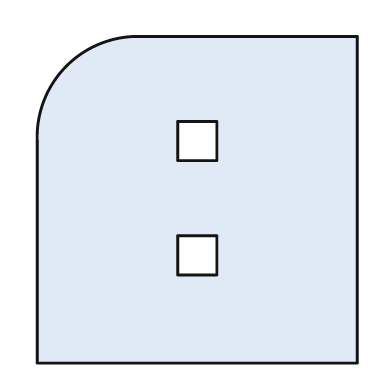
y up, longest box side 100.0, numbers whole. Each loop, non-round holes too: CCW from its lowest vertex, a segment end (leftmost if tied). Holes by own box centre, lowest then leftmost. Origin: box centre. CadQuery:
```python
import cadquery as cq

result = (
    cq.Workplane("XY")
    .moveTo(-49.0, -50.0)
    .lineTo(49.0, -50.0)
    .lineTo(49.0, 50.0)
    .lineTo(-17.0, 50.0)
    .threePointArc((-40.0, 41.0), (-49.0, 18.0))
    .close()
    .moveTo(-6.0, -23.0)
    .lineTo(6.0, -23.0)
    .lineTo(6.0, -11.0)
    .lineTo(-6.0, -11.0)
    .close()
    .moveTo(-6.0, 12.0)
    .lineTo(6.0, 12.0)
    .lineTo(6.0, 24.0)
    .lineTo(-6.0, 24.0)
    .close()
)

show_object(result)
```